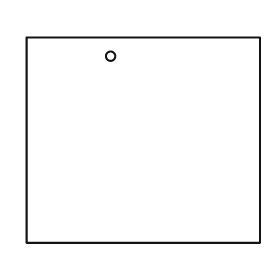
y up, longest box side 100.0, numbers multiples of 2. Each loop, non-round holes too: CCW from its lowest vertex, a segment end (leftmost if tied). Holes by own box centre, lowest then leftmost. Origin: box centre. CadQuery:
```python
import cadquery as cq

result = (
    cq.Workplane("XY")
    .moveTo(-50.0, -44.0)
    .lineTo(50.0, -44.0)
    .lineTo(50.0, 44.0)
    .lineTo(-50.0, 44.0)
    .close()
    .moveTo(-14.0, 36.0)
    .circle(2.0)
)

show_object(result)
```